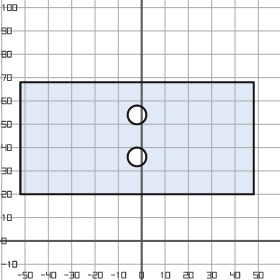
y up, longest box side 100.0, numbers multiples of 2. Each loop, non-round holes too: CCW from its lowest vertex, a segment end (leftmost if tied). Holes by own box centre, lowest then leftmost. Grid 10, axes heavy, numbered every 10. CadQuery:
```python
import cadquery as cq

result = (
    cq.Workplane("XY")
    .moveTo(-52.0, 20.0)
    .lineTo(48.0, 20.0)
    .lineTo(48.0, 68.0)
    .lineTo(-52.0, 68.0)
    .close()
    .moveTo(-2.0, 36.0)
    .circle(4.0)
    .moveTo(-2.0, 54.0)
    .circle(4.0)
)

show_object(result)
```